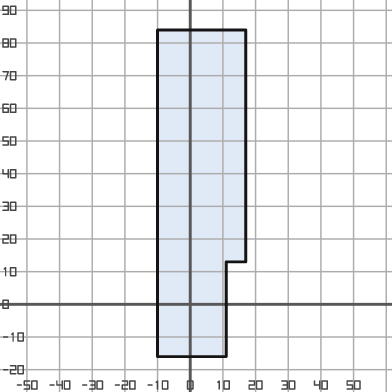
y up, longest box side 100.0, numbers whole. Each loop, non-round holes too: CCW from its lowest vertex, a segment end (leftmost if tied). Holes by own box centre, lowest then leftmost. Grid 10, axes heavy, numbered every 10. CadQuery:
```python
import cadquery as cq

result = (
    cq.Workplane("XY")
    .moveTo(-10.0, -16.0)
    .lineTo(11.0, -16.0)
    .lineTo(11.0, 13.0)
    .lineTo(17.0, 13.0)
    .lineTo(17.0, 84.0)
    .lineTo(-10.0, 84.0)
    .close()
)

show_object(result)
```